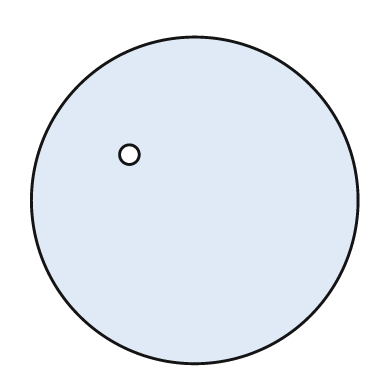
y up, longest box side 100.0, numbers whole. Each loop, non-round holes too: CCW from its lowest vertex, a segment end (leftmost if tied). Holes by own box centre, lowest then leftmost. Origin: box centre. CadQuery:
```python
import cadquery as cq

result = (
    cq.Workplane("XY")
    .moveTo(0.0, 0.0)
    .circle(50.0)
    .moveTo(-20.0, 14.0)
    .circle(3.0)
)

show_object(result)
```